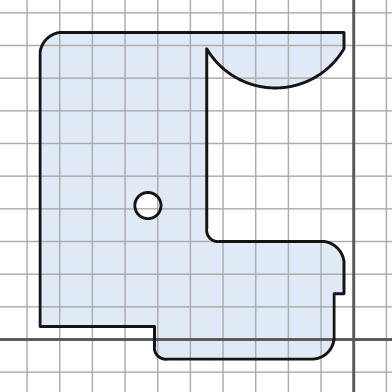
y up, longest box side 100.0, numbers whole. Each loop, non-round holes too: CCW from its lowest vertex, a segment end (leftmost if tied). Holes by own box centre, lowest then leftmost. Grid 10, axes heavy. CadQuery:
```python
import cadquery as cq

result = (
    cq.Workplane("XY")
    .moveTo(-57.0, -6.0)
    .lineTo(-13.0, -6.0)
    .threePointArc((-8.0, -4.0), (-6.0, 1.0))
    .lineTo(-6.0, 14.0)
    .lineTo(-3.0, 14.0)
    .lineTo(-3.0, 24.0)
    .threePointArc((-5.0, 28.0), (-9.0, 30.0))
    .lineTo(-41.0, 30.0)
    .threePointArc((-44.0, 31.0), (-45.0, 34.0))
    .lineTo(-45.0, 89.0)
    .threePointArc((-24.0, 77.0), (-3.0, 89.0))
    .lineTo(-3.0, 94.0)
    .lineTo(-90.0, 94.0)
    .threePointArc((-94.0, 92.0), (-96.0, 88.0))
    .lineTo(-96.0, 4.0)
    .lineTo(-61.0, 4.0)
    .lineTo(-61.0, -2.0)
    .threePointArc((-60.0, -5.0), (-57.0, -6.0))
    .close()
    .moveTo(-63.0, 41.0)
    .circle(4.0)
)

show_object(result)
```